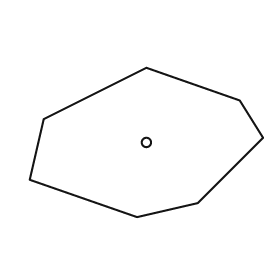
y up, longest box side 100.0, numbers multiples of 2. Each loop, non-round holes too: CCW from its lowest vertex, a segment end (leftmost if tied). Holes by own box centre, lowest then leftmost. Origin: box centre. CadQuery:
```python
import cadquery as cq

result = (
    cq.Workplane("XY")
    .moveTo(-4.0, -32.0)
    .lineTo(22.0, -26.0)
    .lineTo(50.0, 2.0)
    .lineTo(40.0, 18.0)
    .lineTo(0.0, 32.0)
    .lineTo(-44.0, 10.0)
    .lineTo(-50.0, -16.0)
    .close()
    .moveTo(0.0, 0.0)
    .circle(2.0)
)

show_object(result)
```